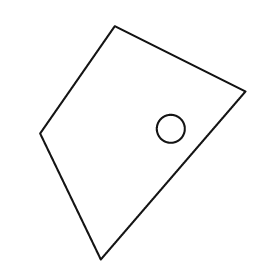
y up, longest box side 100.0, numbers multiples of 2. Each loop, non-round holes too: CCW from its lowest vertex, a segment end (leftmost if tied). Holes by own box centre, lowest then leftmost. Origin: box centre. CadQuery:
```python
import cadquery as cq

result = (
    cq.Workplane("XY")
    .moveTo(-18.0, -50.0)
    .lineTo(44.0, 22.0)
    .lineTo(-12.0, 50.0)
    .lineTo(-44.0, 4.0)
    .close()
    .moveTo(12.0, 6.0)
    .circle(6.0)
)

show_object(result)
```